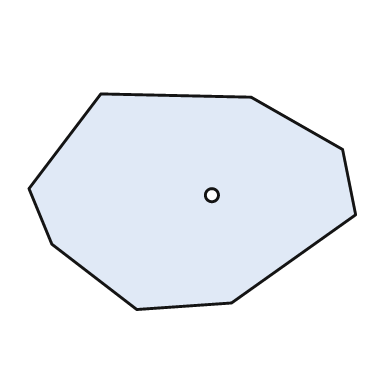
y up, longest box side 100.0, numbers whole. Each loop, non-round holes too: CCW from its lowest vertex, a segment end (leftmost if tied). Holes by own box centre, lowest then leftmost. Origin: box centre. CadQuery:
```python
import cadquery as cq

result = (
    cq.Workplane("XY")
    .moveTo(-17.0, -33.0)
    .lineTo(12.0, -31.0)
    .lineTo(50.0, -4.0)
    .lineTo(46.0, 16.0)
    .lineTo(18.0, 32.0)
    .lineTo(-28.0, 33.0)
    .lineTo(-50.0, 4.0)
    .lineTo(-43.0, -13.0)
    .close()
    .moveTo(6.0, 2.0)
    .circle(2.0)
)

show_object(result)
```